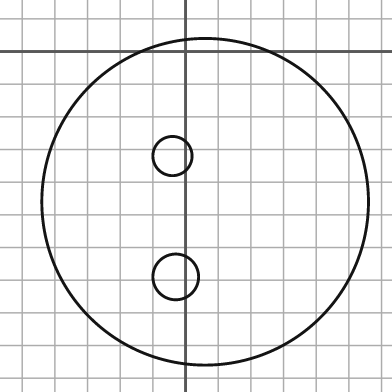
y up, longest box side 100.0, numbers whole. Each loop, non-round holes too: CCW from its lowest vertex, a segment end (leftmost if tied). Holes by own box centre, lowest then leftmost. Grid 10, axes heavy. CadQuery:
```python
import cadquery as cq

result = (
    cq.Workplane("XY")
    .moveTo(6.0, -46.0)
    .circle(50.0)
    .moveTo(-3.0, -69.0)
    .circle(7.0)
    .moveTo(-4.0, -32.0)
    .circle(6.0)
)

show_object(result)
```